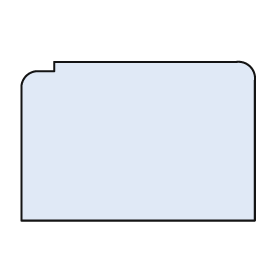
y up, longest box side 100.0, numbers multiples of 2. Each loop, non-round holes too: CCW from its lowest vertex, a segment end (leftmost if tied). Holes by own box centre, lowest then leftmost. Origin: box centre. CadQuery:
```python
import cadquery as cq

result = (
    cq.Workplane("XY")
    .moveTo(-50.0, -34.0)
    .lineTo(50.0, -34.0)
    .lineTo(50.0, 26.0)
    .threePointArc((48.0, 32.0), (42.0, 34.0))
    .lineTo(-36.0, 34.0)
    .lineTo(-36.0, 30.0)
    .lineTo(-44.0, 30.0)
    .threePointArc((-48.0, 28.0), (-50.0, 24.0))
    .close()
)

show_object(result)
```